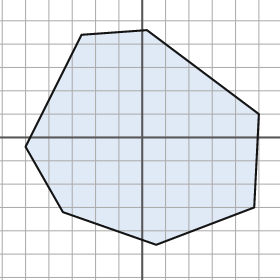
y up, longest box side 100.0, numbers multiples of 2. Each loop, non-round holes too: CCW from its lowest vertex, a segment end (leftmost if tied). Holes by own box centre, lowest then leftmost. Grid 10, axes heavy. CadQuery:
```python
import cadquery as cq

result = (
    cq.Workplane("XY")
    .moveTo(6.0, -46.0)
    .lineTo(48.0, -30.0)
    .lineTo(50.0, 10.0)
    .lineTo(2.0, 46.0)
    .lineTo(-26.0, 44.0)
    .lineTo(-50.0, -4.0)
    .lineTo(-34.0, -32.0)
    .close()
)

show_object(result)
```